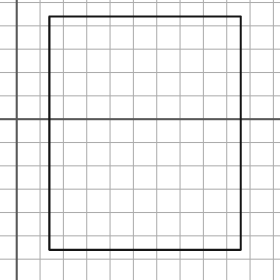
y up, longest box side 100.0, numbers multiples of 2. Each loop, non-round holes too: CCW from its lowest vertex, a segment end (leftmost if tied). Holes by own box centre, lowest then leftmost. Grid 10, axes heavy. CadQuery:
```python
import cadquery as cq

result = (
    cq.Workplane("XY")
    .moveTo(14.0, -56.0)
    .lineTo(96.0, -56.0)
    .lineTo(96.0, 44.0)
    .lineTo(14.0, 44.0)
    .close()
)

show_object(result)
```